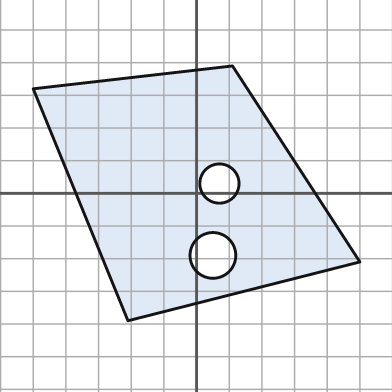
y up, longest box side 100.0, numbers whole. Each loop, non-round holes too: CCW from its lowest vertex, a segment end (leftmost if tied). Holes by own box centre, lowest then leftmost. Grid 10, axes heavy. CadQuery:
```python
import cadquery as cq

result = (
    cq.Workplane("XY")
    .moveTo(-21.0, -39.0)
    .lineTo(50.0, -21.0)
    .lineTo(11.0, 39.0)
    .lineTo(-50.0, 32.0)
    .close()
    .moveTo(5.0, -19.0)
    .circle(7.0)
    .moveTo(7.0, 3.0)
    .circle(6.0)
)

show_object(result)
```